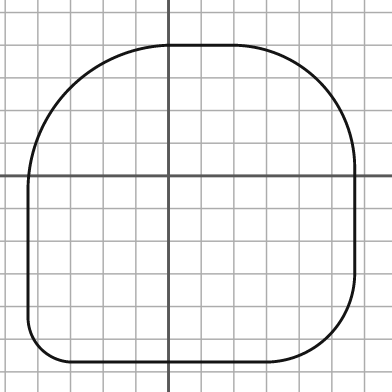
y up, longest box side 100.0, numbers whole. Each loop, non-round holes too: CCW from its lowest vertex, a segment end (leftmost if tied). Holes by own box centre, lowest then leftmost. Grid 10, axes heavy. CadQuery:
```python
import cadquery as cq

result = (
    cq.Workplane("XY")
    .moveTo(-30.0, -57.0)
    .lineTo(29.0, -57.0)
    .threePointArc((49.0, -49.0), (57.0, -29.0))
    .lineTo(57.0, 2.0)
    .threePointArc((46.0, 29.0), (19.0, 40.0))
    .lineTo(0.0, 40.0)
    .threePointArc((-30.0, 27.0), (-43.0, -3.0))
    .lineTo(-43.0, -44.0)
    .threePointArc((-39.0, -53.0), (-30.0, -57.0))
    .close()
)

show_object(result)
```